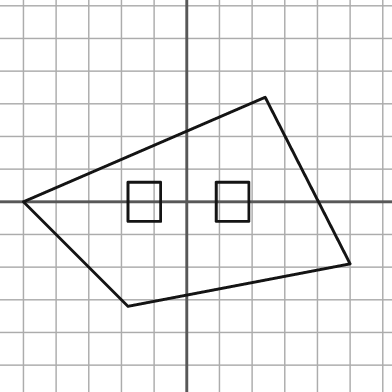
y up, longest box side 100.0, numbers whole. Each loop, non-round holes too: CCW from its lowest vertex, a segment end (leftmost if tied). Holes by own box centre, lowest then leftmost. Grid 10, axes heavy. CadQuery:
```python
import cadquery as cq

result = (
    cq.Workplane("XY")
    .moveTo(-18.0, -32.0)
    .lineTo(50.0, -19.0)
    .lineTo(24.0, 32.0)
    .lineTo(-50.0, 0.0)
    .close()
    .moveTo(-18.0, -6.0)
    .lineTo(-8.0, -6.0)
    .lineTo(-8.0, 6.0)
    .lineTo(-18.0, 6.0)
    .close()
    .moveTo(9.0, -6.0)
    .lineTo(19.0, -6.0)
    .lineTo(19.0, 6.0)
    .lineTo(9.0, 6.0)
    .close()
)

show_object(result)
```